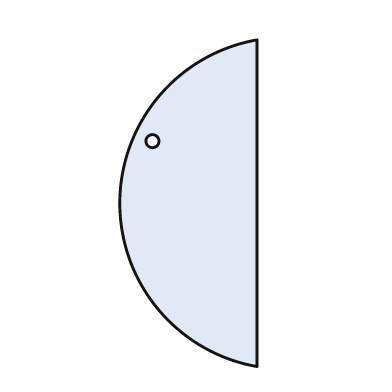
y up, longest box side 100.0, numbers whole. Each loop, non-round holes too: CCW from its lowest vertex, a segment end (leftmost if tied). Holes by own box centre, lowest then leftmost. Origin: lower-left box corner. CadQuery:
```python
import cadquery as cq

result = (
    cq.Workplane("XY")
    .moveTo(42.0, 0.0)
    .lineTo(42.0, 100.0)
    .threePointArc((0.0, 50.0), (42.0, 0.0))
    .close()
    .moveTo(10.0, 69.0)
    .circle(2.0)
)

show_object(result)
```